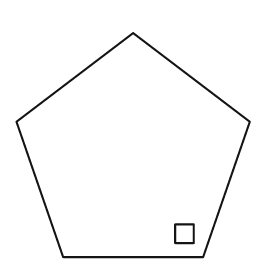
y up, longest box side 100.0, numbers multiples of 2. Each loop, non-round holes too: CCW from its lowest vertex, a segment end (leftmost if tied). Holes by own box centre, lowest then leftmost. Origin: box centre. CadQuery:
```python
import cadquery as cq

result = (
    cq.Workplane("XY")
    .moveTo(-30.0, -48.0)
    .lineTo(30.0, -48.0)
    .lineTo(50.0, 10.0)
    .lineTo(0.0, 48.0)
    .lineTo(-50.0, 10.0)
    .close()
    .moveTo(18.0, -42.0)
    .lineTo(26.0, -42.0)
    .lineTo(26.0, -34.0)
    .lineTo(18.0, -34.0)
    .close()
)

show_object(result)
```